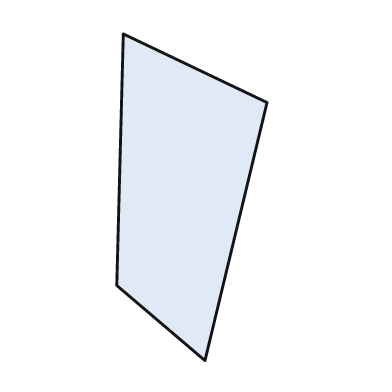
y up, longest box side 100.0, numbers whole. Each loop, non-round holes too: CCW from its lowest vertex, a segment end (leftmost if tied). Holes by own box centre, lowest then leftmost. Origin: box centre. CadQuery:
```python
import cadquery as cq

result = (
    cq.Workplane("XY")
    .moveTo(4.0, -50.0)
    .lineTo(23.0, 29.0)
    .lineTo(-21.0, 50.0)
    .lineTo(-23.0, -27.0)
    .close()
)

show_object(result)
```